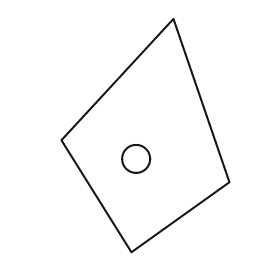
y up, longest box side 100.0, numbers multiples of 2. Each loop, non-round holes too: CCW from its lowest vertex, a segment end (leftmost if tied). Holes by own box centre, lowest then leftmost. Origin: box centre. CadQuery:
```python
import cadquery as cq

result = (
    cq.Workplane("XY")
    .moveTo(-6.0, -50.0)
    .lineTo(36.0, -20.0)
    .lineTo(12.0, 50.0)
    .lineTo(-36.0, -2.0)
    .close()
    .moveTo(-4.0, -10.0)
    .circle(6.0)
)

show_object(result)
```